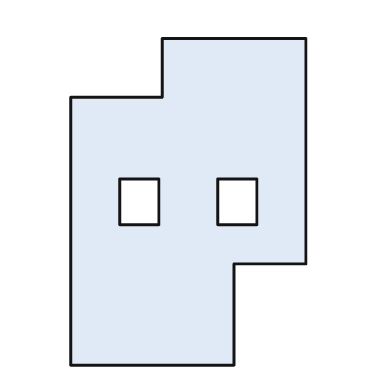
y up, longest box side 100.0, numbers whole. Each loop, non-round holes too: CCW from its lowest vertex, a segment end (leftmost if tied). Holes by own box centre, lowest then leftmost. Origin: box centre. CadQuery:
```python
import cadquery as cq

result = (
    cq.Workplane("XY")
    .moveTo(-36.0, -50.0)
    .lineTo(14.0, -50.0)
    .lineTo(14.0, -19.0)
    .lineTo(36.0, -19.0)
    .lineTo(36.0, 50.0)
    .lineTo(-8.0, 50.0)
    .lineTo(-8.0, 32.0)
    .lineTo(-36.0, 32.0)
    .close()
    .moveTo(-21.0, -7.0)
    .lineTo(-9.0, -7.0)
    .lineTo(-9.0, 7.0)
    .lineTo(-21.0, 7.0)
    .close()
    .moveTo(9.0, -7.0)
    .lineTo(21.0, -7.0)
    .lineTo(21.0, 7.0)
    .lineTo(9.0, 7.0)
    .close()
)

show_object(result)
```